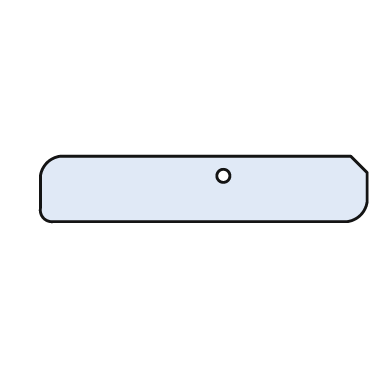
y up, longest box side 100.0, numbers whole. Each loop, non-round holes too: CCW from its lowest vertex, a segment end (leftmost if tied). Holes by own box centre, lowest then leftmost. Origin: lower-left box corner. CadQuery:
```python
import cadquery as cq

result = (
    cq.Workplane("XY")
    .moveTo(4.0, 0.0)
    .lineTo(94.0, 0.0)
    .threePointArc((98.0, 2.0), (100.0, 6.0))
    .lineTo(100.0, 15.0)
    .lineTo(95.0, 20.0)
    .lineTo(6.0, 20.0)
    .threePointArc((2.0, 18.0), (0.0, 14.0))
    .lineTo(0.0, 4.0)
    .threePointArc((1.0, 1.0), (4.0, 0.0))
    .close()
    .moveTo(56.0, 14.0)
    .circle(2.0)
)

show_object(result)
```